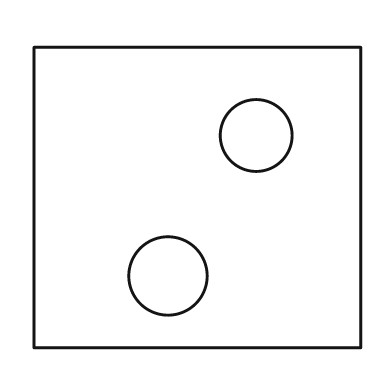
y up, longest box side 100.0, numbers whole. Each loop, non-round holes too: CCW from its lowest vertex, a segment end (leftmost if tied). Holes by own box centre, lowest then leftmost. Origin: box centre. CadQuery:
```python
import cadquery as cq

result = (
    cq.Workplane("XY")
    .moveTo(-50.0, -46.0)
    .lineTo(50.0, -46.0)
    .lineTo(50.0, 46.0)
    .lineTo(-50.0, 46.0)
    .close()
    .moveTo(-9.0, -24.0)
    .circle(12.0)
    .moveTo(18.0, 19.0)
    .circle(11.0)
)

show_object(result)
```